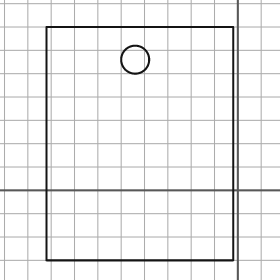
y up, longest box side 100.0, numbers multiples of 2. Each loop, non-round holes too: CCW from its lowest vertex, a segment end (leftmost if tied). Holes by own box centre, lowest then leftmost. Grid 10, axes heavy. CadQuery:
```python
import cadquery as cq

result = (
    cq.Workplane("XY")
    .moveTo(-82.0, -30.0)
    .lineTo(-2.0, -30.0)
    .lineTo(-2.0, 70.0)
    .lineTo(-82.0, 70.0)
    .close()
    .moveTo(-44.0, 56.0)
    .circle(6.0)
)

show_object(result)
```